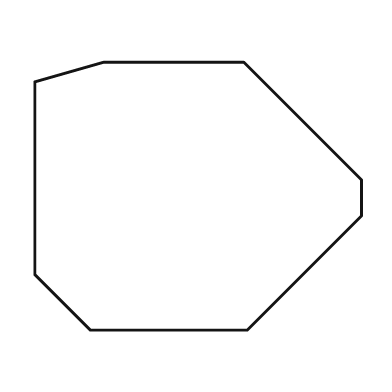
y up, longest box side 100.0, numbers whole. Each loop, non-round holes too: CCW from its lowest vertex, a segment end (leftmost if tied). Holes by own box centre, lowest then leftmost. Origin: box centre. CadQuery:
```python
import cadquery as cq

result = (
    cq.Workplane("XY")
    .moveTo(-33.0, -41.0)
    .lineTo(15.0, -41.0)
    .lineTo(50.0, -6.0)
    .lineTo(50.0, 5.0)
    .lineTo(14.0, 41.0)
    .lineTo(-29.0, 41.0)
    .lineTo(-50.0, 35.0)
    .lineTo(-50.0, -24.0)
    .close()
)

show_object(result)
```